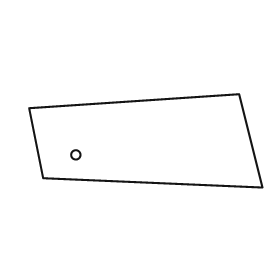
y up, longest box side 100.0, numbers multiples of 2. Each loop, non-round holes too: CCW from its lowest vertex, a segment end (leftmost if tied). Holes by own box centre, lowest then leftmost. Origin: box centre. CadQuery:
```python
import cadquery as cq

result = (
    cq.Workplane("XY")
    .moveTo(50.0, -20.0)
    .lineTo(40.0, 20.0)
    .lineTo(-50.0, 14.0)
    .lineTo(-44.0, -16.0)
    .close()
    .moveTo(-30.0, -6.0)
    .circle(2.0)
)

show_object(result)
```